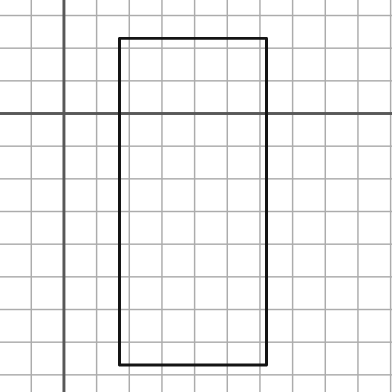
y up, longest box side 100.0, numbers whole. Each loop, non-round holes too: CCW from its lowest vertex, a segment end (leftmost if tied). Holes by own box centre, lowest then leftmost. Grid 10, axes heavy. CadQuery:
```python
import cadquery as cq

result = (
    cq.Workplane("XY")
    .moveTo(17.0, -77.0)
    .lineTo(62.0, -77.0)
    .lineTo(62.0, 23.0)
    .lineTo(17.0, 23.0)
    .close()
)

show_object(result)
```